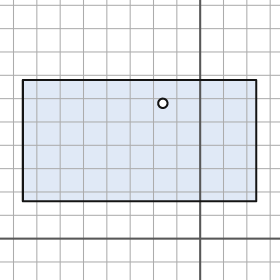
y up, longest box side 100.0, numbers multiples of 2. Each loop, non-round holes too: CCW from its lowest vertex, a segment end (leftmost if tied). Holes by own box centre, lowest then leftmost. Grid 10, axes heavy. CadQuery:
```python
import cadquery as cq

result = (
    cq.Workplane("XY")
    .moveTo(-76.0, 16.0)
    .lineTo(24.0, 16.0)
    .lineTo(24.0, 68.0)
    .lineTo(-76.0, 68.0)
    .close()
    .moveTo(-16.0, 58.0)
    .circle(2.0)
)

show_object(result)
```